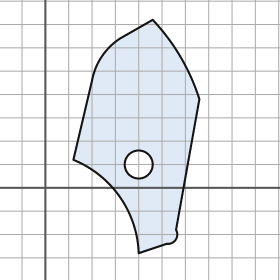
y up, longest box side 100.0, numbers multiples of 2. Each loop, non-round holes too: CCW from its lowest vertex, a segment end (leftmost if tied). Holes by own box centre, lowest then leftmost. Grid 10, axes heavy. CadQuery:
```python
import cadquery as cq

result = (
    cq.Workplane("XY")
    .moveTo(40.0, -28.0)
    .lineTo(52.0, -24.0)
    .threePointArc((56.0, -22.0), (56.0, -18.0))
    .lineTo(66.0, 38.0)
    .threePointArc((58.0, 56.0), (46.0, 72.0))
    .lineTo(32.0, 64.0)
    .threePointArc((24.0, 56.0), (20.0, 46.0))
    .lineTo(12.0, 12.0)
    .threePointArc((32.0, -4.0), (40.0, -28.0))
    .close()
    .moveTo(40.0, 10.0)
    .circle(6.0)
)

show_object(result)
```